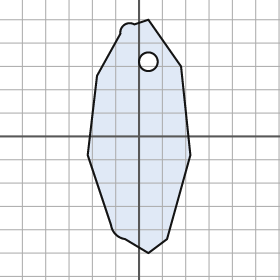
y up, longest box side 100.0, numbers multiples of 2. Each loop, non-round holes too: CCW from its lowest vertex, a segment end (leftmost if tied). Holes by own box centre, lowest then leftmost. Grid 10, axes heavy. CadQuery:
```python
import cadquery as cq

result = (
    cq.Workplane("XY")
    .moveTo(4.0, -50.0)
    .lineTo(12.0, -44.0)
    .lineTo(22.0, -8.0)
    .lineTo(18.0, 30.0)
    .lineTo(4.0, 50.0)
    .lineTo(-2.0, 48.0)
    .threePointArc((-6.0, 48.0), (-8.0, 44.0))
    .lineTo(-18.0, 26.0)
    .lineTo(-22.0, -8.0)
    .lineTo(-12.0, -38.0)
    .threePointArc((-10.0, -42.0), (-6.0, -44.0))
    .close()
    .moveTo(4.0, 32.0)
    .circle(4.0)
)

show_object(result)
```